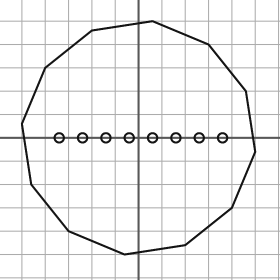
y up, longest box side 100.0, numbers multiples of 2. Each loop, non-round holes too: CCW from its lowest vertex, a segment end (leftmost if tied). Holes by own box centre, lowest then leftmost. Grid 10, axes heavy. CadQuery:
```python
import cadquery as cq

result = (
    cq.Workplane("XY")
    .moveTo(-6.0, -50.0)
    .lineTo(20.0, -46.0)
    .lineTo(40.0, -30.0)
    .lineTo(50.0, -6.0)
    .lineTo(46.0, 20.0)
    .lineTo(30.0, 40.0)
    .lineTo(6.0, 50.0)
    .lineTo(-20.0, 46.0)
    .lineTo(-40.0, 30.0)
    .lineTo(-50.0, 6.0)
    .lineTo(-46.0, -20.0)
    .lineTo(-30.0, -40.0)
    .close()
    .moveTo(-34.0, 0.0)
    .circle(2.0)
    .moveTo(-24.0, 0.0)
    .circle(2.0)
    .moveTo(-14.0, 0.0)
    .circle(2.0)
    .moveTo(-4.0, 0.0)
    .circle(2.0)
    .moveTo(6.0, 0.0)
    .circle(2.0)
    .moveTo(16.0, 0.0)
    .circle(2.0)
    .moveTo(26.0, 0.0)
    .circle(2.0)
    .moveTo(36.0, 0.0)
    .circle(2.0)
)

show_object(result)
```